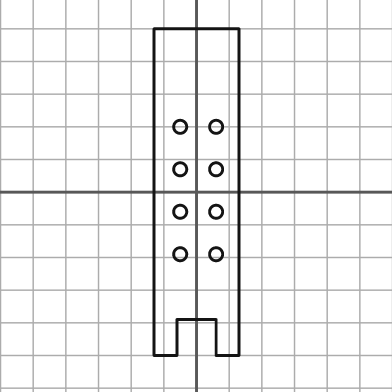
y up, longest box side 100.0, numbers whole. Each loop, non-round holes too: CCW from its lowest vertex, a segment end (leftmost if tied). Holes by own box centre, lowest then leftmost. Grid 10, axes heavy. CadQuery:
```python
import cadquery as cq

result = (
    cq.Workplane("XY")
    .moveTo(-13.0, -50.0)
    .lineTo(-6.0, -50.0)
    .lineTo(-6.0, -39.0)
    .lineTo(6.0, -39.0)
    .lineTo(6.0, -50.0)
    .lineTo(13.0, -50.0)
    .lineTo(13.0, 50.0)
    .lineTo(-13.0, 50.0)
    .close()
    .moveTo(-5.0, -19.0)
    .circle(2.0)
    .moveTo(6.0, -19.0)
    .circle(2.0)
    .moveTo(-5.0, -6.0)
    .circle(2.0)
    .moveTo(6.0, -6.0)
    .circle(2.0)
    .moveTo(-5.0, 7.0)
    .circle(2.0)
    .moveTo(6.0, 7.0)
    .circle(2.0)
    .moveTo(-5.0, 20.0)
    .circle(2.0)
    .moveTo(6.0, 20.0)
    .circle(2.0)
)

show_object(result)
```